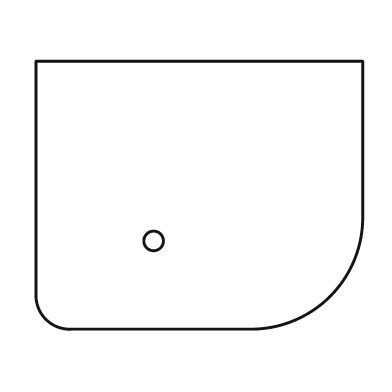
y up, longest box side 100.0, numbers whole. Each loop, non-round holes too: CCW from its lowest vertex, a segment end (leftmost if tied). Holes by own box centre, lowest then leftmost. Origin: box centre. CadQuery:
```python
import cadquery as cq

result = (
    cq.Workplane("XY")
    .moveTo(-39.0, -41.0)
    .lineTo(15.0, -41.0)
    .threePointArc((40.0, -31.0), (50.0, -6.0))
    .lineTo(50.0, 41.0)
    .lineTo(-50.0, 41.0)
    .lineTo(-50.0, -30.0)
    .threePointArc((-47.0, -38.0), (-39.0, -41.0))
    .close()
    .moveTo(-14.0, -14.0)
    .circle(3.0)
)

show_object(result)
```